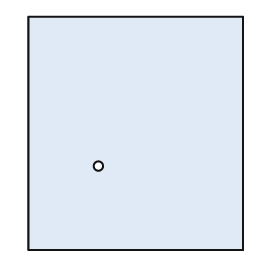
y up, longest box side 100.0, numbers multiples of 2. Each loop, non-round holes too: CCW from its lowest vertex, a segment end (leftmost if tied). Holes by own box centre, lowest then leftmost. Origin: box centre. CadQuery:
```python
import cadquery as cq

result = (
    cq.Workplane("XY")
    .moveTo(-46.0, -50.0)
    .lineTo(46.0, -50.0)
    .lineTo(46.0, 50.0)
    .lineTo(-46.0, 50.0)
    .close()
    .moveTo(-16.0, -14.0)
    .circle(2.0)
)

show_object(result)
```